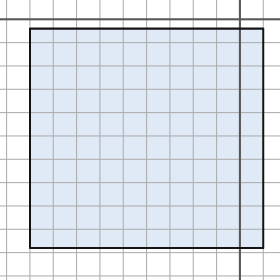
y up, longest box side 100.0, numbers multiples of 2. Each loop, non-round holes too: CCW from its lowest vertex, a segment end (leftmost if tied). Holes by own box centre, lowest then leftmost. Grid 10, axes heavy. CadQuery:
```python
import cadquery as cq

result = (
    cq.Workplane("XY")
    .moveTo(-90.0, -98.0)
    .lineTo(10.0, -98.0)
    .lineTo(10.0, -4.0)
    .lineTo(-90.0, -4.0)
    .close()
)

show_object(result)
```